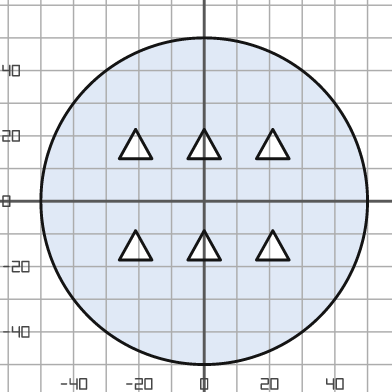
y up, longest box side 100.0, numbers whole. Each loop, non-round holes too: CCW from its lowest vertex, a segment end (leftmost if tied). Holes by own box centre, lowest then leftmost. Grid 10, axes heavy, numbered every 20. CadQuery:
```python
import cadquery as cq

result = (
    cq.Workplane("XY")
    .moveTo(0.0, 0.0)
    .circle(50.0)
    .moveTo(-26.0, -18.0)
    .lineTo(-16.0, -18.0)
    .lineTo(-21.0, -9.0)
    .close()
    .moveTo(-5.0, -18.0)
    .lineTo(5.0, -18.0)
    .lineTo(0.0, -9.0)
    .close()
    .moveTo(16.0, -18.0)
    .lineTo(26.0, -18.0)
    .lineTo(21.0, -9.0)
    .close()
    .moveTo(-26.0, 13.0)
    .lineTo(-16.0, 13.0)
    .lineTo(-21.0, 22.0)
    .close()
    .moveTo(-5.0, 13.0)
    .lineTo(5.0, 13.0)
    .lineTo(0.0, 22.0)
    .close()
    .moveTo(16.0, 13.0)
    .lineTo(26.0, 13.0)
    .lineTo(21.0, 22.0)
    .close()
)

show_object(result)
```